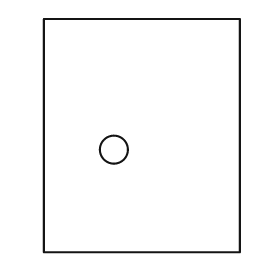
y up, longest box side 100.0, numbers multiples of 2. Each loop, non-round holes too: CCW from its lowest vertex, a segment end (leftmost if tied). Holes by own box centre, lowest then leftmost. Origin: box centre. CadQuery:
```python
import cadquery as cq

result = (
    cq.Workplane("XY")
    .moveTo(-42.0, -50.0)
    .lineTo(42.0, -50.0)
    .lineTo(42.0, 50.0)
    .lineTo(-42.0, 50.0)
    .close()
    .moveTo(-12.0, -6.0)
    .circle(6.0)
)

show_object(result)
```